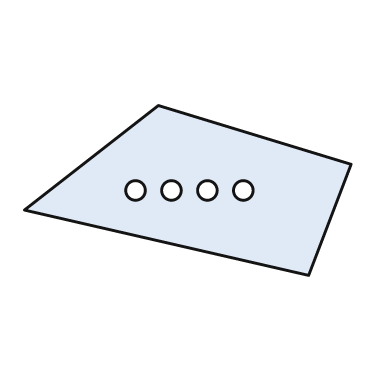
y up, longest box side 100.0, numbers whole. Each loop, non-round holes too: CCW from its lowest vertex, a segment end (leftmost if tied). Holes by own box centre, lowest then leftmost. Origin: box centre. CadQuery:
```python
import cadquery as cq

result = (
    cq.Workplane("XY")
    .moveTo(37.0, -26.0)
    .lineTo(50.0, 8.0)
    .lineTo(-9.0, 26.0)
    .lineTo(-50.0, -6.0)
    .close()
    .moveTo(-16.0, 0.0)
    .circle(3.0)
    .moveTo(-5.0, 0.0)
    .circle(3.0)
    .moveTo(6.0, 0.0)
    .circle(3.0)
    .moveTo(17.0, 0.0)
    .circle(3.0)
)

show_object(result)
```